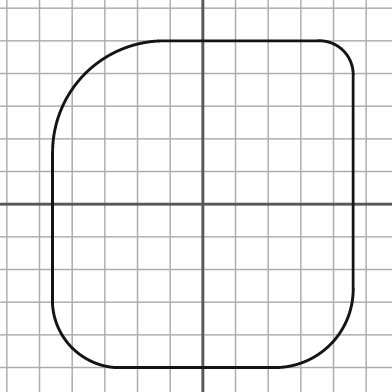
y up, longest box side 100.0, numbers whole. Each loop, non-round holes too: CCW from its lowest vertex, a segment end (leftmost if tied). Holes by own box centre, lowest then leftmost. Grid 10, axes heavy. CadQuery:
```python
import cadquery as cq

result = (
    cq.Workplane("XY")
    .moveTo(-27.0, -50.0)
    .lineTo(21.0, -50.0)
    .threePointArc((39.0, -43.0), (46.0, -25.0))
    .lineTo(46.0, 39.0)
    .threePointArc((43.0, 47.0), (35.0, 50.0))
    .lineTo(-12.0, 50.0)
    .threePointArc((-36.0, 40.0), (-46.0, 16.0))
    .lineTo(-46.0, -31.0)
    .threePointArc((-40.0, -44.0), (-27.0, -50.0))
    .close()
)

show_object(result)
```